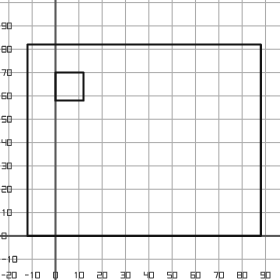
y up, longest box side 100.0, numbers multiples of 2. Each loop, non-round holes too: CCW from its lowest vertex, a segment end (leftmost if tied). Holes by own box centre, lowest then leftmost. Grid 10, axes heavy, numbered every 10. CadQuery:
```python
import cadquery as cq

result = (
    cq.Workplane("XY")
    .moveTo(-12.0, 0.0)
    .lineTo(88.0, 0.0)
    .lineTo(88.0, 82.0)
    .lineTo(-12.0, 82.0)
    .close()
    .moveTo(0.0, 58.0)
    .lineTo(12.0, 58.0)
    .lineTo(12.0, 70.0)
    .lineTo(0.0, 70.0)
    .close()
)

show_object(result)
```